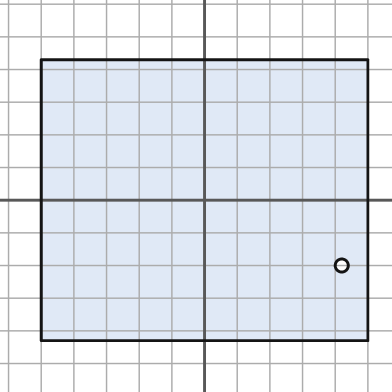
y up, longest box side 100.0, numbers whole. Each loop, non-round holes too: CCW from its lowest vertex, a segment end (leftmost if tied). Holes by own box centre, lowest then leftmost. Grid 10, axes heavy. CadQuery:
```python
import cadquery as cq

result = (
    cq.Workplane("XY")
    .moveTo(-50.0, -43.0)
    .lineTo(50.0, -43.0)
    .lineTo(50.0, 43.0)
    .lineTo(-50.0, 43.0)
    .close()
    .moveTo(42.0, -20.0)
    .circle(2.0)
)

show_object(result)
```